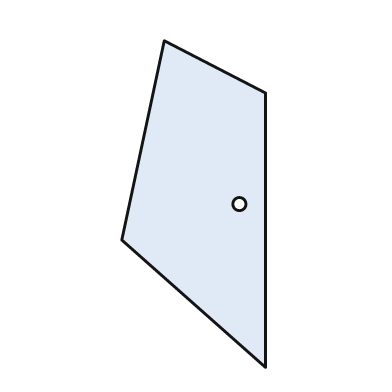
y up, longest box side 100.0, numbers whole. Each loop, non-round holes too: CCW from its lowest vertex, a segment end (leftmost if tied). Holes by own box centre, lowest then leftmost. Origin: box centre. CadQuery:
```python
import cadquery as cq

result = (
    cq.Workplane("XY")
    .moveTo(22.0, -50.0)
    .lineTo(22.0, 34.0)
    .lineTo(-9.0, 50.0)
    .lineTo(-22.0, -11.0)
    .close()
    .moveTo(14.0, 0.0)
    .circle(2.0)
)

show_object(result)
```